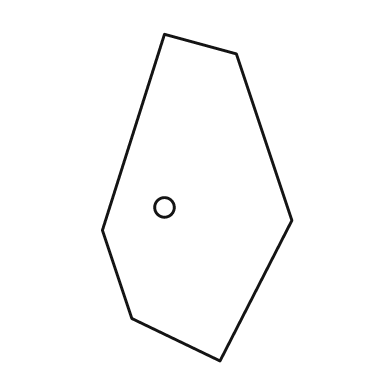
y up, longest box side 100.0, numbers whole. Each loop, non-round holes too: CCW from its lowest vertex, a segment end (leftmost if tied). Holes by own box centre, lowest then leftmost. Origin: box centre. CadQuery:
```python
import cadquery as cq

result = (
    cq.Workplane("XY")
    .moveTo(7.0, -50.0)
    .lineTo(29.0, -7.0)
    .lineTo(12.0, 44.0)
    .lineTo(-10.0, 50.0)
    .lineTo(-29.0, -10.0)
    .lineTo(-20.0, -37.0)
    .close()
    .moveTo(-10.0, -3.0)
    .circle(3.0)
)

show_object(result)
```